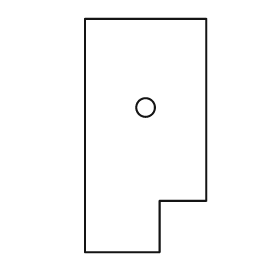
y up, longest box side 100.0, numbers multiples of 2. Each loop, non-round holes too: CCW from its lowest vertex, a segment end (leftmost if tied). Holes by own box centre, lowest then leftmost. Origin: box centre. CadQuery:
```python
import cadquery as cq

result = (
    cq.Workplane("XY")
    .moveTo(-26.0, -50.0)
    .lineTo(6.0, -50.0)
    .lineTo(6.0, -28.0)
    .lineTo(26.0, -28.0)
    .lineTo(26.0, 50.0)
    .lineTo(-26.0, 50.0)
    .close()
    .moveTo(0.0, 12.0)
    .circle(4.0)
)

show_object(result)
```